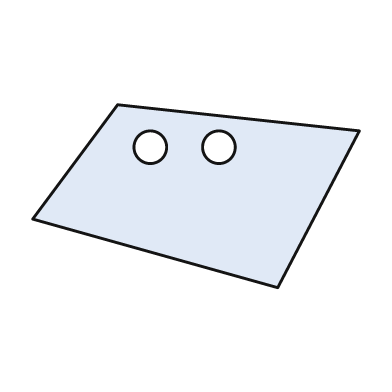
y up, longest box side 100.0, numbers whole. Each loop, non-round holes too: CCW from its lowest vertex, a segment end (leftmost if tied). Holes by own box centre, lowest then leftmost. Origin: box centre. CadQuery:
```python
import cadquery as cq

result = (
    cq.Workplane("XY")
    .moveTo(25.0, -28.0)
    .lineTo(50.0, 20.0)
    .lineTo(-24.0, 28.0)
    .lineTo(-50.0, -7.0)
    .close()
    .moveTo(-14.0, 15.0)
    .circle(5.0)
    .moveTo(7.0, 15.0)
    .circle(5.0)
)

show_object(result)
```